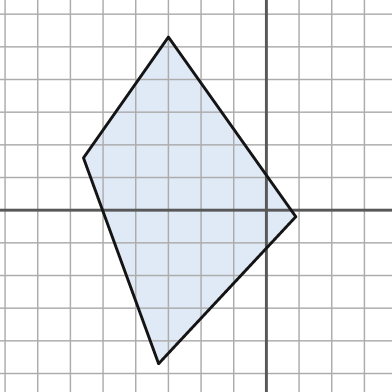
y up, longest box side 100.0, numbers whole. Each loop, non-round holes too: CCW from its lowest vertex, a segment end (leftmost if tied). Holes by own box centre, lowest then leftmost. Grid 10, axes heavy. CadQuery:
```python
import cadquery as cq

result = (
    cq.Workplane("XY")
    .moveTo(-33.0, -47.0)
    .lineTo(9.0, -2.0)
    .lineTo(-30.0, 53.0)
    .lineTo(-56.0, 16.0)
    .close()
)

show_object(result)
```